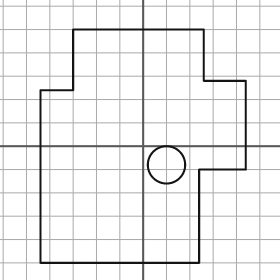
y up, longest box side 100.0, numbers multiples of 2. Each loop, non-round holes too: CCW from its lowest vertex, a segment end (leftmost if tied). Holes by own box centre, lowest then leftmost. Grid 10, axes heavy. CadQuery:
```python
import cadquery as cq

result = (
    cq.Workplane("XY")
    .moveTo(-44.0, -50.0)
    .lineTo(24.0, -50.0)
    .lineTo(24.0, -10.0)
    .lineTo(44.0, -10.0)
    .lineTo(44.0, 28.0)
    .lineTo(26.0, 28.0)
    .lineTo(26.0, 50.0)
    .lineTo(-30.0, 50.0)
    .lineTo(-30.0, 24.0)
    .lineTo(-44.0, 24.0)
    .close()
    .moveTo(10.0, -8.0)
    .circle(8.0)
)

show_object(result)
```